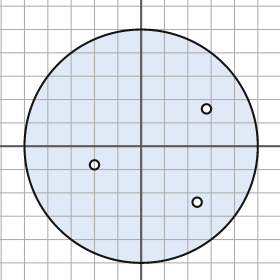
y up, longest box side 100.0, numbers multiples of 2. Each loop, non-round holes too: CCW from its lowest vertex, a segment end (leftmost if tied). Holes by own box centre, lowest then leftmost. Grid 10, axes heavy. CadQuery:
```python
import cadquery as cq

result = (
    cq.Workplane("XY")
    .moveTo(0.0, 0.0)
    .circle(50.0)
    .moveTo(24.0, -24.0)
    .circle(2.0)
    .moveTo(-20.0, -8.0)
    .circle(2.0)
    .moveTo(28.0, 16.0)
    .circle(2.0)
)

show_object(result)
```